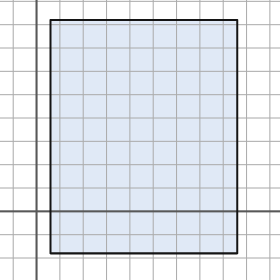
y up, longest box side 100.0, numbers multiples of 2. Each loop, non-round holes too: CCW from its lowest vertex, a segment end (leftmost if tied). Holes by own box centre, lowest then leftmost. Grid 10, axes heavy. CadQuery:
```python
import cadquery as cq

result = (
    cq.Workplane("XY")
    .moveTo(6.0, -18.0)
    .lineTo(86.0, -18.0)
    .lineTo(86.0, 82.0)
    .lineTo(6.0, 82.0)
    .close()
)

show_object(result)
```